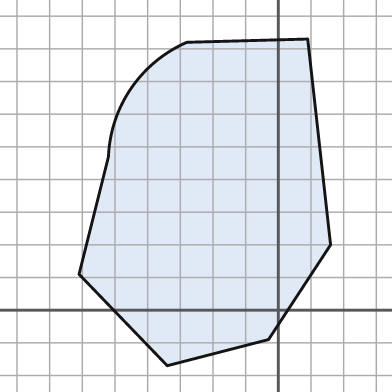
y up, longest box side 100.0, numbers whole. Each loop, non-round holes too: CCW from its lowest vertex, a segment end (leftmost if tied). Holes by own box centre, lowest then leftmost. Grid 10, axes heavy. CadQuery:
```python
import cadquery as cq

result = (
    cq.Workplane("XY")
    .moveTo(-34.0, -17.0)
    .lineTo(-3.0, -9.0)
    .lineTo(16.0, 20.0)
    .lineTo(9.0, 83.0)
    .lineTo(-28.0, 82.0)
    .threePointArc((-45.0, 68.0), (-52.0, 47.0))
    .lineTo(-61.0, 11.0)
    .close()
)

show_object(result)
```